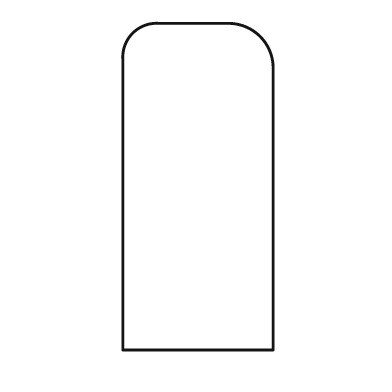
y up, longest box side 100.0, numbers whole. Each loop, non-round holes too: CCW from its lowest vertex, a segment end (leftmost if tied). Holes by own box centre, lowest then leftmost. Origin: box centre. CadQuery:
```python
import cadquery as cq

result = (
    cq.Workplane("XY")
    .moveTo(-23.0, -50.0)
    .lineTo(23.0, -50.0)
    .lineTo(23.0, 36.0)
    .threePointArc((19.0, 46.0), (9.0, 50.0))
    .lineTo(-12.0, 50.0)
    .threePointArc((-20.0, 47.0), (-23.0, 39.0))
    .close()
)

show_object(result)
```